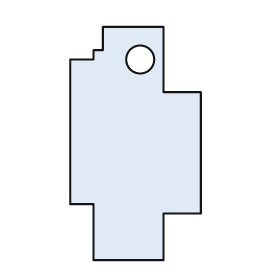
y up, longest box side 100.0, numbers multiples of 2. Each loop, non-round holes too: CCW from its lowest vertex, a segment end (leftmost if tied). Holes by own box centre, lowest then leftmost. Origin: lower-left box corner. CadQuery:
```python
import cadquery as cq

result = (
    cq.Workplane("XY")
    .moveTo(10.0, 0.0)
    .lineTo(40.0, 0.0)
    .lineTo(40.0, 20.0)
    .lineTo(56.0, 20.0)
    .lineTo(56.0, 72.0)
    .lineTo(40.0, 72.0)
    .lineTo(40.0, 100.0)
    .lineTo(14.0, 100.0)
    .lineTo(14.0, 90.0)
    .lineTo(10.0, 90.0)
    .lineTo(10.0, 86.0)
    .lineTo(0.0, 86.0)
    .lineTo(0.0, 24.0)
    .lineTo(10.0, 24.0)
    .close()
    .moveTo(30.0, 86.0)
    .circle(6.0)
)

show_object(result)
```